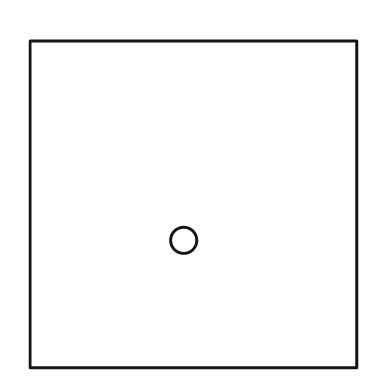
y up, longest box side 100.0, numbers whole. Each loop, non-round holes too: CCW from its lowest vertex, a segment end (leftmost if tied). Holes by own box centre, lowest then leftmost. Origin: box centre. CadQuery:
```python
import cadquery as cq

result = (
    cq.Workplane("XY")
    .moveTo(-50.0, -50.0)
    .lineTo(50.0, -50.0)
    .lineTo(50.0, 50.0)
    .lineTo(-50.0, 50.0)
    .close()
    .moveTo(-3.0, -11.0)
    .circle(4.0)
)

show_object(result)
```